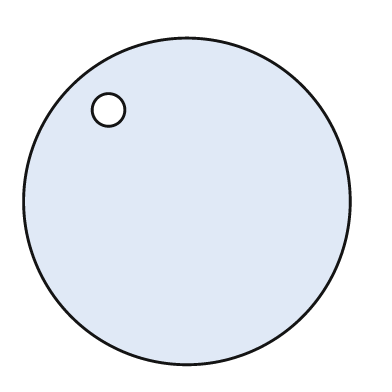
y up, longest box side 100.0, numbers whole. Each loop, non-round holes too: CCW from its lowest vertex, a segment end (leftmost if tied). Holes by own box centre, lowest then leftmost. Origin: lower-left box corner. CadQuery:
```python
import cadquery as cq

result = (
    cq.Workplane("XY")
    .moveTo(50.0, 50.0)
    .circle(50.0)
    .moveTo(26.0, 78.0)
    .circle(5.0)
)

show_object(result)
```